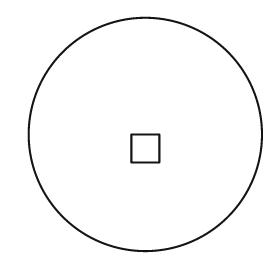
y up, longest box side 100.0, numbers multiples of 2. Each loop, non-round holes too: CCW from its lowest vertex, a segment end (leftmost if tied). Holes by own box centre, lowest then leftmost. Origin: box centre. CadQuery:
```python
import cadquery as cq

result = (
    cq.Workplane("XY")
    .moveTo(0.0, 0.0)
    .circle(50.0)
    .moveTo(-6.0, -12.0)
    .lineTo(6.0, -12.0)
    .lineTo(6.0, 0.0)
    .lineTo(-6.0, 0.0)
    .close()
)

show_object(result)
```